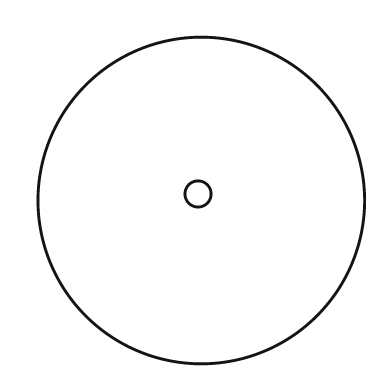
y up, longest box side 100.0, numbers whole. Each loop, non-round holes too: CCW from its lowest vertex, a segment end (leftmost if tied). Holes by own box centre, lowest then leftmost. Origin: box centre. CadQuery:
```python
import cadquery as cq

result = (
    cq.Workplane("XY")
    .moveTo(0.0, 0.0)
    .circle(50.0)
    .moveTo(-1.0, 2.0)
    .circle(4.0)
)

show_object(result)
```